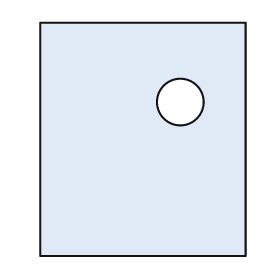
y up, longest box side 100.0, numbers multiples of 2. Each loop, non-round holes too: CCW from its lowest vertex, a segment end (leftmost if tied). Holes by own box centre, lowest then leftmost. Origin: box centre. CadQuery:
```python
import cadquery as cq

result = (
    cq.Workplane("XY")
    .moveTo(-44.0, -50.0)
    .lineTo(44.0, -50.0)
    .lineTo(44.0, 50.0)
    .lineTo(-44.0, 50.0)
    .close()
    .moveTo(16.0, 16.0)
    .circle(10.0)
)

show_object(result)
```